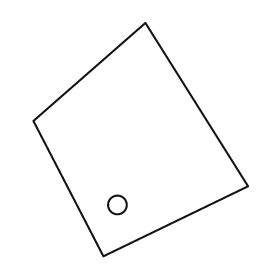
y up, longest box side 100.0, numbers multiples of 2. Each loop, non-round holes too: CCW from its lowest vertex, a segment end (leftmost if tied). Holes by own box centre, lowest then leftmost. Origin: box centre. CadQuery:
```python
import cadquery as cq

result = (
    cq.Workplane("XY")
    .moveTo(-16.0, -50.0)
    .lineTo(46.0, -20.0)
    .lineTo(2.0, 50.0)
    .lineTo(-46.0, 8.0)
    .close()
    .moveTo(-10.0, -28.0)
    .circle(4.0)
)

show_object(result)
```